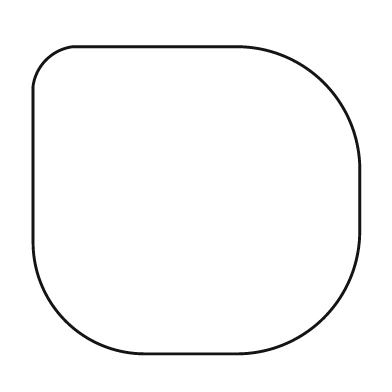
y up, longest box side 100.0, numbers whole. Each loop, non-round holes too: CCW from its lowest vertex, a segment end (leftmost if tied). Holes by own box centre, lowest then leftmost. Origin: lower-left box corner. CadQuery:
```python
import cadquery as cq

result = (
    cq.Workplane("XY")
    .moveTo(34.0, 0.0)
    .lineTo(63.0, 0.0)
    .threePointArc((89.0, 11.0), (100.0, 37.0))
    .lineTo(100.0, 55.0)
    .threePointArc((89.0, 83.0), (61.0, 94.0))
    .lineTo(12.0, 94.0)
    .threePointArc((4.0, 90.0), (0.0, 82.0))
    .lineTo(0.0, 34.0)
    .threePointArc((10.0, 10.0), (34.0, 0.0))
    .close()
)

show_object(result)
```